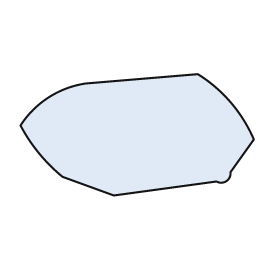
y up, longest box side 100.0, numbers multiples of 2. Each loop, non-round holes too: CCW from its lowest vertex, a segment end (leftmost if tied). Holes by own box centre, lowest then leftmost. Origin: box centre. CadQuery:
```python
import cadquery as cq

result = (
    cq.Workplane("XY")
    .moveTo(-10.0, -26.0)
    .lineTo(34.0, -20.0)
    .threePointArc((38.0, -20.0), (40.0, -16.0))
    .lineTo(50.0, -2.0)
    .threePointArc((40.0, 14.0), (26.0, 26.0))
    .lineTo(-22.0, 22.0)
    .threePointArc((-38.0, 16.0), (-50.0, 4.0))
    .threePointArc((-42.0, -8.0), (-32.0, -18.0))
    .close()
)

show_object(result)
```